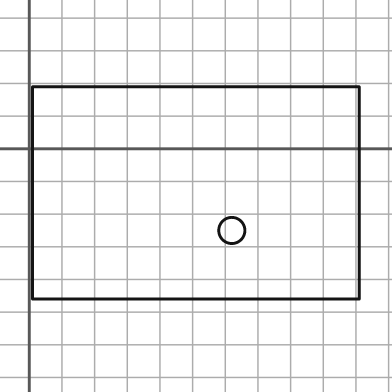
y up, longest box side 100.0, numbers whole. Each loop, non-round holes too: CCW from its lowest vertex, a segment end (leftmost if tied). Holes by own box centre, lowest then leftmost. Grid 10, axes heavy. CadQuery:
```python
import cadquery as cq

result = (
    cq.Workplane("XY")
    .moveTo(1.0, -46.0)
    .lineTo(101.0, -46.0)
    .lineTo(101.0, 19.0)
    .lineTo(1.0, 19.0)
    .close()
    .moveTo(62.0, -25.0)
    .circle(4.0)
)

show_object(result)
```